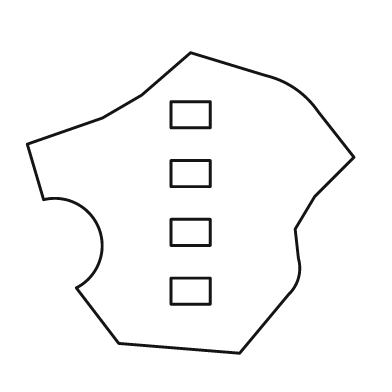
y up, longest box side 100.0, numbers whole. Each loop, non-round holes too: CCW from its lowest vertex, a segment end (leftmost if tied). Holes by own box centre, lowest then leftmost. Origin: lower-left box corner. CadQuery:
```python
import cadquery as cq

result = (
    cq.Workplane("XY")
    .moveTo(65.0, 0.0)
    .lineTo(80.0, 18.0)
    .threePointArc((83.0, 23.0), (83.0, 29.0))
    .lineTo(82.0, 38.0)
    .lineTo(88.0, 48.0)
    .lineTo(100.0, 60.0)
    .lineTo(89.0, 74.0)
    .threePointArc((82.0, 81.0), (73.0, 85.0))
    .lineTo(50.0, 92.0)
    .lineTo(35.0, 79.0)
    .lineTo(23.0, 72.0)
    .lineTo(0.0, 64.0)
    .lineTo(5.0, 47.0)
    .threePointArc((22.0, 38.0), (15.0, 20.0))
    .lineTo(28.0, 3.0)
    .close()
    .moveTo(44.0, 15.0)
    .lineTo(56.0, 15.0)
    .lineTo(56.0, 23.0)
    .lineTo(44.0, 23.0)
    .close()
    .moveTo(44.0, 33.0)
    .lineTo(56.0, 33.0)
    .lineTo(56.0, 41.0)
    .lineTo(44.0, 41.0)
    .close()
    .moveTo(44.0, 51.0)
    .lineTo(56.0, 51.0)
    .lineTo(56.0, 59.0)
    .lineTo(44.0, 59.0)
    .close()
    .moveTo(44.0, 69.0)
    .lineTo(56.0, 69.0)
    .lineTo(56.0, 77.0)
    .lineTo(44.0, 77.0)
    .close()
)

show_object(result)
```